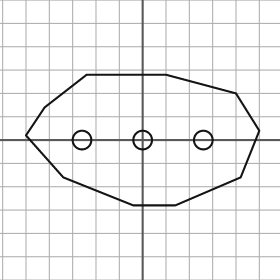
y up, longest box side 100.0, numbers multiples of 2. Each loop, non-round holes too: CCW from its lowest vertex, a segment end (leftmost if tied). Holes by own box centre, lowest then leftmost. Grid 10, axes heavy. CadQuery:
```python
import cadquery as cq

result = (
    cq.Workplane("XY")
    .moveTo(-4.0, -28.0)
    .lineTo(14.0, -28.0)
    .lineTo(42.0, -16.0)
    .lineTo(50.0, 4.0)
    .lineTo(40.0, 20.0)
    .lineTo(10.0, 28.0)
    .lineTo(-24.0, 28.0)
    .lineTo(-42.0, 14.0)
    .lineTo(-50.0, 2.0)
    .lineTo(-34.0, -16.0)
    .close()
    .moveTo(-26.0, 0.0)
    .circle(4.0)
    .moveTo(0.0, 0.0)
    .circle(4.0)
    .moveTo(26.0, 0.0)
    .circle(4.0)
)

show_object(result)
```